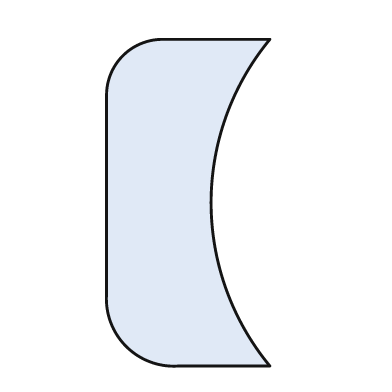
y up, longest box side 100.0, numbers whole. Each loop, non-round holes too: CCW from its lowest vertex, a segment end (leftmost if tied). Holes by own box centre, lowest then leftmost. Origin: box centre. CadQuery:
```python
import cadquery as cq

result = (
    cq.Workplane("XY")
    .moveTo(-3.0, -50.0)
    .lineTo(25.0, -50.0)
    .threePointArc((7.0, 0.0), (25.0, 50.0))
    .lineTo(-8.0, 50.0)
    .threePointArc((-20.0, 45.0), (-25.0, 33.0))
    .lineTo(-25.0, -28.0)
    .threePointArc((-19.0, -44.0), (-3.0, -50.0))
    .close()
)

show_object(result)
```